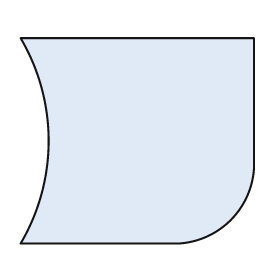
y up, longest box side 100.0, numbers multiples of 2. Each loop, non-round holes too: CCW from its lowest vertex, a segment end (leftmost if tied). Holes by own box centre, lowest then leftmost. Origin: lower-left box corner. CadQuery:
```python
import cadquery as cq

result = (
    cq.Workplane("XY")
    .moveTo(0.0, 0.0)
    .lineTo(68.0, 0.0)
    .threePointArc((90.0, 10.0), (100.0, 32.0))
    .lineTo(100.0, 88.0)
    .lineTo(0.0, 88.0)
    .threePointArc((12.0, 44.0), (0.0, 0.0))
    .close()
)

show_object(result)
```